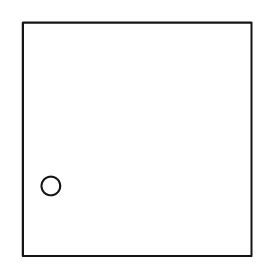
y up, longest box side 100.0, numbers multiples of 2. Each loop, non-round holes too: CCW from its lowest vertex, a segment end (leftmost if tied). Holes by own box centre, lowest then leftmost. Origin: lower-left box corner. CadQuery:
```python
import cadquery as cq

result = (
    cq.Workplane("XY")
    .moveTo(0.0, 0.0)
    .lineTo(98.0, 0.0)
    .lineTo(98.0, 100.0)
    .lineTo(0.0, 100.0)
    .close()
    .moveTo(12.0, 30.0)
    .circle(4.0)
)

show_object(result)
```